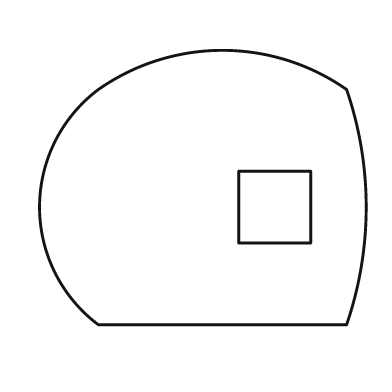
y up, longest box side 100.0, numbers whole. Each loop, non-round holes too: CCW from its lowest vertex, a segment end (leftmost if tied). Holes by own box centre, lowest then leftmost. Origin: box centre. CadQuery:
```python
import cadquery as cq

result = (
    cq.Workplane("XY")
    .moveTo(-32.0, -42.0)
    .lineTo(44.0, -42.0)
    .threePointArc((50.0, -6.0), (44.0, 30.0))
    .threePointArc((6.0, 42.0), (-32.0, 30.0))
    .threePointArc((-50.0, -6.0), (-32.0, -42.0))
    .close()
    .moveTo(11.0, -17.0)
    .lineTo(33.0, -17.0)
    .lineTo(33.0, 5.0)
    .lineTo(11.0, 5.0)
    .close()
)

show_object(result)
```